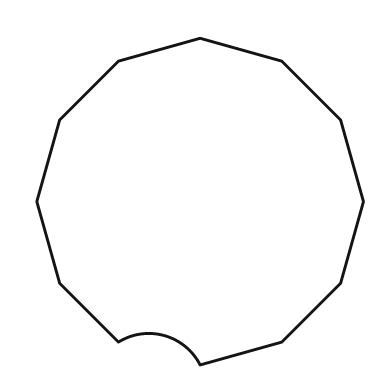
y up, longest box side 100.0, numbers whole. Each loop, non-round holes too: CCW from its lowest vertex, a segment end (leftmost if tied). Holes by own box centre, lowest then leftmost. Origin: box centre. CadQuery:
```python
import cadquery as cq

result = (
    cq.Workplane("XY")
    .moveTo(0.0, -50.0)
    .lineTo(25.0, -43.0)
    .lineTo(43.0, -25.0)
    .lineTo(50.0, 0.0)
    .lineTo(43.0, 25.0)
    .lineTo(25.0, 43.0)
    .lineTo(0.0, 50.0)
    .lineTo(-25.0, 43.0)
    .lineTo(-43.0, 25.0)
    .lineTo(-50.0, 0.0)
    .lineTo(-43.0, -25.0)
    .lineTo(-25.0, -43.0)
    .threePointArc((-11.0, -41.0), (0.0, -50.0))
    .close()
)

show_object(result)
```